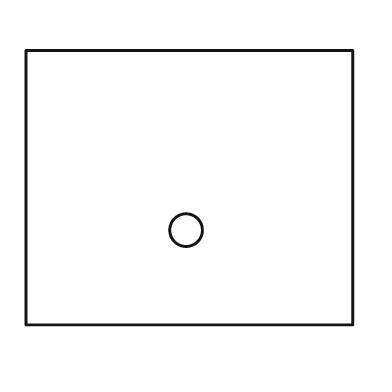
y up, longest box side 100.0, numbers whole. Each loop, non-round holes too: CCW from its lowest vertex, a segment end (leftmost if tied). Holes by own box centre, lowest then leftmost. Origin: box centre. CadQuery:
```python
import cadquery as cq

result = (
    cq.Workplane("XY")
    .moveTo(-50.0, -42.0)
    .lineTo(50.0, -42.0)
    .lineTo(50.0, 42.0)
    .lineTo(-50.0, 42.0)
    .close()
    .moveTo(-1.0, -13.0)
    .circle(5.0)
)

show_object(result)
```